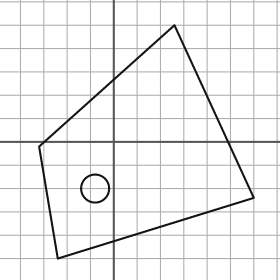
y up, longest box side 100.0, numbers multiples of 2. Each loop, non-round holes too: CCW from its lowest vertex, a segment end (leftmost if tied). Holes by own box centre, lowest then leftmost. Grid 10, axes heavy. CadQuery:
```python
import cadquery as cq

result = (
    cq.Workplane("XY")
    .moveTo(-24.0, -50.0)
    .lineTo(60.0, -24.0)
    .lineTo(26.0, 50.0)
    .lineTo(-32.0, -2.0)
    .close()
    .moveTo(-8.0, -20.0)
    .circle(6.0)
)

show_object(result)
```